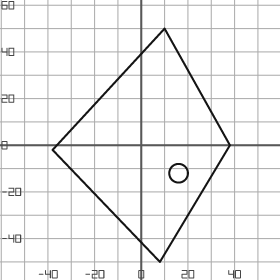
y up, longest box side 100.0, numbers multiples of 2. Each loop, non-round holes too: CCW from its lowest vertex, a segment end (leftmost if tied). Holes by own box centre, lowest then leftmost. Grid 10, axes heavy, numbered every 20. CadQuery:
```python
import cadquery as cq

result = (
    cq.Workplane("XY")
    .moveTo(8.0, -50.0)
    .lineTo(38.0, 0.0)
    .lineTo(10.0, 50.0)
    .lineTo(-38.0, -2.0)
    .close()
    .moveTo(16.0, -12.0)
    .circle(4.0)
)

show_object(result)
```